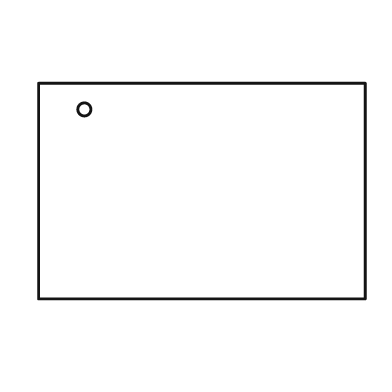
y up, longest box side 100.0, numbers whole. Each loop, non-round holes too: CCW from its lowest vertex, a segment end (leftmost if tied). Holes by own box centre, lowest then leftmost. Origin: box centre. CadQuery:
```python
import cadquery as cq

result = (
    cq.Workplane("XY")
    .moveTo(-50.0, -33.0)
    .lineTo(50.0, -33.0)
    .lineTo(50.0, 33.0)
    .lineTo(-50.0, 33.0)
    .close()
    .moveTo(-36.0, 25.0)
    .circle(2.0)
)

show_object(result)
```